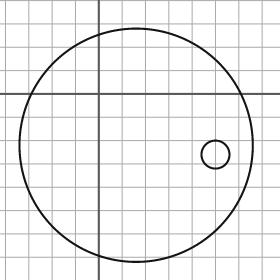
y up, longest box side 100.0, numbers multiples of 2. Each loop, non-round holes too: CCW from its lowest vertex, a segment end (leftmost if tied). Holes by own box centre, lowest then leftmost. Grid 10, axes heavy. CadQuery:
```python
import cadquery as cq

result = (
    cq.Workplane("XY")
    .moveTo(16.0, -22.0)
    .circle(50.0)
    .moveTo(50.0, -26.0)
    .circle(6.0)
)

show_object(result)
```